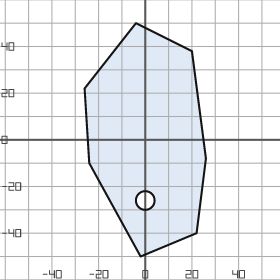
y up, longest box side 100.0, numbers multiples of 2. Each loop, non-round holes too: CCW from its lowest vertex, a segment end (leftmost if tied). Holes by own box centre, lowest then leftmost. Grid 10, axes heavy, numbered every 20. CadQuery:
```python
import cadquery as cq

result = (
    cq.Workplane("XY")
    .moveTo(-2.0, -50.0)
    .lineTo(22.0, -40.0)
    .lineTo(26.0, -8.0)
    .lineTo(20.0, 38.0)
    .lineTo(-4.0, 50.0)
    .lineTo(-26.0, 22.0)
    .lineTo(-24.0, -10.0)
    .close()
    .moveTo(0.0, -26.0)
    .circle(4.0)
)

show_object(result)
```